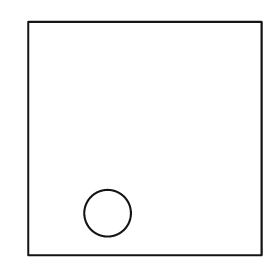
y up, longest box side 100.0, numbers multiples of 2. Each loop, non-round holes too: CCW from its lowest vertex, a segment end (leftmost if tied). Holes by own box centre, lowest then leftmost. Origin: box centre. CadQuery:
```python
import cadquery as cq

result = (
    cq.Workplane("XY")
    .moveTo(-50.0, -50.0)
    .lineTo(50.0, -50.0)
    .lineTo(50.0, 50.0)
    .lineTo(-50.0, 50.0)
    .close()
    .moveTo(-16.0, -32.0)
    .circle(10.0)
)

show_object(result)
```